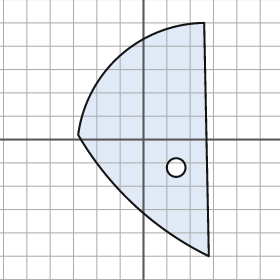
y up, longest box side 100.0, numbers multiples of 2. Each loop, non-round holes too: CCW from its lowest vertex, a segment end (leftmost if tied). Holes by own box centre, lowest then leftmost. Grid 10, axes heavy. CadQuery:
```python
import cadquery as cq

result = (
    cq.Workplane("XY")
    .moveTo(28.0, -50.0)
    .lineTo(26.0, 50.0)
    .threePointArc((-10.0, 36.0), (-28.0, 2.0))
    .threePointArc((-4.0, -28.0), (28.0, -50.0))
    .close()
    .moveTo(14.0, -12.0)
    .circle(4.0)
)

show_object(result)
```